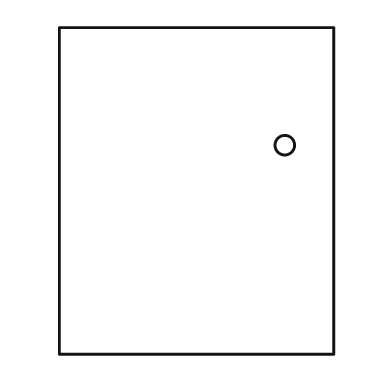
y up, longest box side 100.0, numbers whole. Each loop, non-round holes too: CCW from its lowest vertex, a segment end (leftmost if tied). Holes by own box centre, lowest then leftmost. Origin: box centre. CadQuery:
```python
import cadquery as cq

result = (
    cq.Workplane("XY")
    .moveTo(-42.0, -50.0)
    .lineTo(42.0, -50.0)
    .lineTo(42.0, 50.0)
    .lineTo(-42.0, 50.0)
    .close()
    .moveTo(27.0, 14.0)
    .circle(3.0)
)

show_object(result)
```